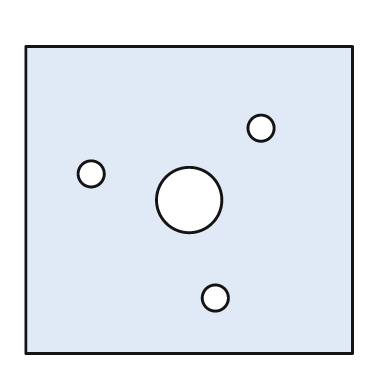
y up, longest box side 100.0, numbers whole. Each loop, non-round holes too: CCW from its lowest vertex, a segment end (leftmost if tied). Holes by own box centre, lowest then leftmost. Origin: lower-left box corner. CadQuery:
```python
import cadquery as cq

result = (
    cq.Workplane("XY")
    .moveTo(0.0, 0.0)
    .lineTo(100.0, 0.0)
    .lineTo(100.0, 94.0)
    .lineTo(0.0, 94.0)
    .close()
    .moveTo(58.0, 17.0)
    .circle(4.0)
    .moveTo(50.0, 47.0)
    .circle(10.0)
    .moveTo(20.0, 55.0)
    .circle(4.0)
    .moveTo(72.0, 69.0)
    .circle(4.0)
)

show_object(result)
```